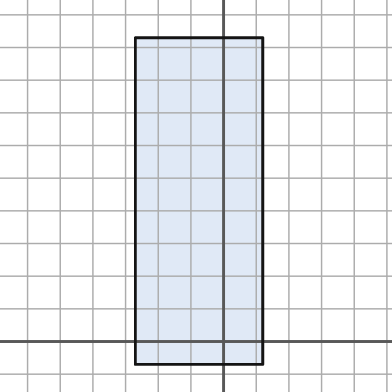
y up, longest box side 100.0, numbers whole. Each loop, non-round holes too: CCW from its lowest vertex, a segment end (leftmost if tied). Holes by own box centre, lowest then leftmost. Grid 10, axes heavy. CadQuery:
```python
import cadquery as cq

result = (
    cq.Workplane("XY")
    .moveTo(-27.0, -7.0)
    .lineTo(12.0, -7.0)
    .lineTo(12.0, 93.0)
    .lineTo(-27.0, 93.0)
    .close()
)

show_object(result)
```